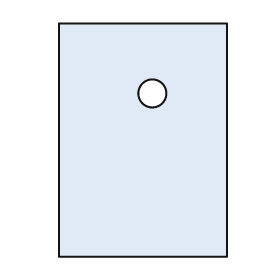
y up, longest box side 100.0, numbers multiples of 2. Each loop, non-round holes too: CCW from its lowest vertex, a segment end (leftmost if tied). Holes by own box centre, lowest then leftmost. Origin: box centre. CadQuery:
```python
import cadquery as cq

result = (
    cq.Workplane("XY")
    .moveTo(-36.0, -50.0)
    .lineTo(36.0, -50.0)
    .lineTo(36.0, 50.0)
    .lineTo(-36.0, 50.0)
    .close()
    .moveTo(4.0, 20.0)
    .circle(6.0)
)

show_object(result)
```